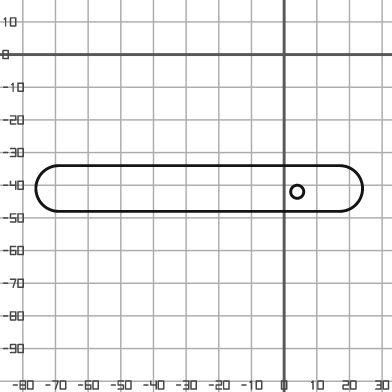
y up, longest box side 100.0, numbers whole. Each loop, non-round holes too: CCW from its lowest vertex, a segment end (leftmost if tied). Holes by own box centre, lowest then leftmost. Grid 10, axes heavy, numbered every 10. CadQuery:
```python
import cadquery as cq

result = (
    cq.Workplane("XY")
    .moveTo(-69.0, -48.0)
    .lineTo(17.0, -48.0)
    .threePointArc((24.0, -41.0), (17.0, -34.0))
    .lineTo(-69.0, -34.0)
    .threePointArc((-76.0, -41.0), (-69.0, -48.0))
    .close()
    .moveTo(4.0, -42.0)
    .circle(2.0)
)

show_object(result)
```